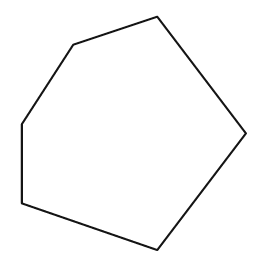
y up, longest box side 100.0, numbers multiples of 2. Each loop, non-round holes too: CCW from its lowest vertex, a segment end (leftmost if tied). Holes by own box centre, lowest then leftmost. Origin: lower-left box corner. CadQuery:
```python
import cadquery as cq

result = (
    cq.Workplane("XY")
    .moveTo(58.0, 0.0)
    .lineTo(96.0, 50.0)
    .lineTo(58.0, 100.0)
    .lineTo(22.0, 88.0)
    .lineTo(0.0, 54.0)
    .lineTo(0.0, 20.0)
    .close()
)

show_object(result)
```